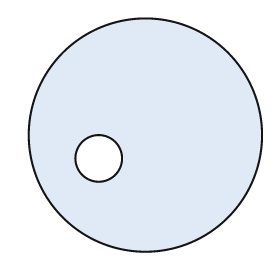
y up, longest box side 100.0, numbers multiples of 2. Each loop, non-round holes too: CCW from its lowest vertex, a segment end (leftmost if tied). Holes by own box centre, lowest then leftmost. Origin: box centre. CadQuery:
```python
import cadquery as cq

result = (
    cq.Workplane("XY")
    .moveTo(0.0, 0.0)
    .circle(50.0)
    .moveTo(-20.0, -10.0)
    .circle(10.0)
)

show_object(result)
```